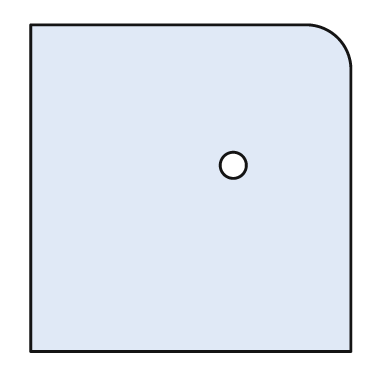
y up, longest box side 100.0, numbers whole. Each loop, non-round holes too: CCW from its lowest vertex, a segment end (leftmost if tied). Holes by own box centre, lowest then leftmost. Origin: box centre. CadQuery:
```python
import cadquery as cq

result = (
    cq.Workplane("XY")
    .moveTo(-49.0, -50.0)
    .lineTo(49.0, -50.0)
    .lineTo(49.0, 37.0)
    .threePointArc((45.0, 46.0), (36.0, 50.0))
    .lineTo(-49.0, 50.0)
    .close()
    .moveTo(13.0, 7.0)
    .circle(4.0)
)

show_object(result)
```